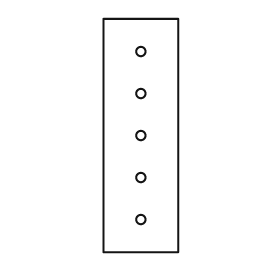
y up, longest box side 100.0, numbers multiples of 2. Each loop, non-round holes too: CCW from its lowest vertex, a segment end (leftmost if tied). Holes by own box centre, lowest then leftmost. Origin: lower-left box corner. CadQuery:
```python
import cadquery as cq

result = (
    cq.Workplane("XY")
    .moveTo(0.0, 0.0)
    .lineTo(32.0, 0.0)
    .lineTo(32.0, 100.0)
    .lineTo(0.0, 100.0)
    .close()
    .moveTo(16.0, 14.0)
    .circle(2.0)
    .moveTo(16.0, 32.0)
    .circle(2.0)
    .moveTo(16.0, 50.0)
    .circle(2.0)
    .moveTo(16.0, 68.0)
    .circle(2.0)
    .moveTo(16.0, 86.0)
    .circle(2.0)
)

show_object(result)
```